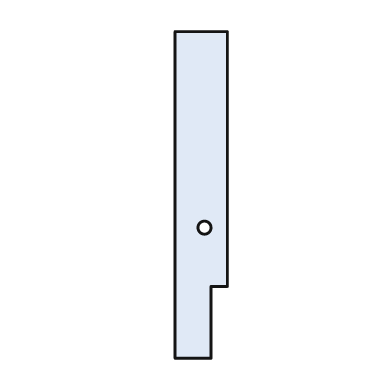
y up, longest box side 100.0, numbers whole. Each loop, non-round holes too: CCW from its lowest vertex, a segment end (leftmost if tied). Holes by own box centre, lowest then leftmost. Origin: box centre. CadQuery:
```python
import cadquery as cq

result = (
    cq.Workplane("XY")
    .moveTo(-8.0, -50.0)
    .lineTo(3.0, -50.0)
    .lineTo(3.0, -28.0)
    .lineTo(8.0, -28.0)
    .lineTo(8.0, 50.0)
    .lineTo(-8.0, 50.0)
    .close()
    .moveTo(1.0, -10.0)
    .circle(2.0)
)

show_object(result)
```